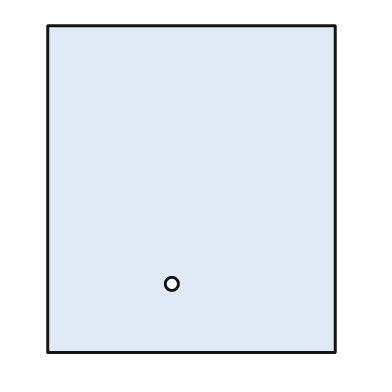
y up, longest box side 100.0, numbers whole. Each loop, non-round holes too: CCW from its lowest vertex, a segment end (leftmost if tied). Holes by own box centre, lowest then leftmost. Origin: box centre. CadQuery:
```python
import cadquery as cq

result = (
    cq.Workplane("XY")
    .moveTo(-44.0, -50.0)
    .lineTo(44.0, -50.0)
    .lineTo(44.0, 50.0)
    .lineTo(-44.0, 50.0)
    .close()
    .moveTo(-6.0, -29.0)
    .circle(2.0)
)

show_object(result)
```